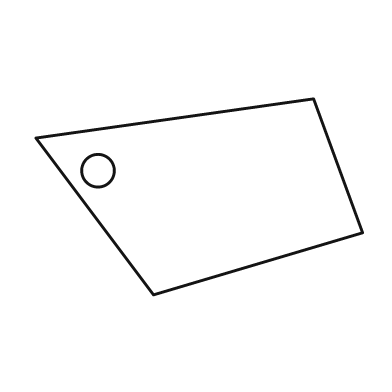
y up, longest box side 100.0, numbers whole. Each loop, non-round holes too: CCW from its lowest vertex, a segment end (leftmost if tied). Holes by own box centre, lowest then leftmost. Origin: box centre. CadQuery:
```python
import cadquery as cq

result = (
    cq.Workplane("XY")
    .moveTo(-14.0, -30.0)
    .lineTo(50.0, -11.0)
    .lineTo(35.0, 30.0)
    .lineTo(-50.0, 18.0)
    .close()
    .moveTo(-31.0, 8.0)
    .circle(5.0)
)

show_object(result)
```